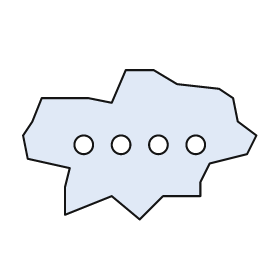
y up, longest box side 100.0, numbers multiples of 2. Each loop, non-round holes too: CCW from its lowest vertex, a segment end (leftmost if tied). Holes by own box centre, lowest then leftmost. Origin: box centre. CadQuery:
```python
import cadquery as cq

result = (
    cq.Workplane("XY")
    .moveTo(0.0, -32.0)
    .lineTo(10.0, -22.0)
    .lineTo(26.0, -22.0)
    .lineTo(26.0, -16.0)
    .lineTo(30.0, -8.0)
    .lineTo(46.0, -4.0)
    .lineTo(50.0, 4.0)
    .lineTo(42.0, 10.0)
    .lineTo(40.0, 20.0)
    .lineTo(34.0, 24.0)
    .lineTo(16.0, 26.0)
    .lineTo(6.0, 32.0)
    .lineTo(-6.0, 32.0)
    .lineTo(-12.0, 18.0)
    .lineTo(-22.0, 20.0)
    .lineTo(-42.0, 20.0)
    .lineTo(-46.0, 10.0)
    .lineTo(-50.0, 4.0)
    .lineTo(-48.0, -6.0)
    .lineTo(-30.0, -10.0)
    .lineTo(-32.0, -18.0)
    .lineTo(-32.0, -30.0)
    .lineTo(-12.0, -22.0)
    .close()
    .moveTo(-24.0, 0.0)
    .circle(4.0)
    .moveTo(-8.0, 0.0)
    .circle(4.0)
    .moveTo(8.0, 0.0)
    .circle(4.0)
    .moveTo(24.0, 0.0)
    .circle(4.0)
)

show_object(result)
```